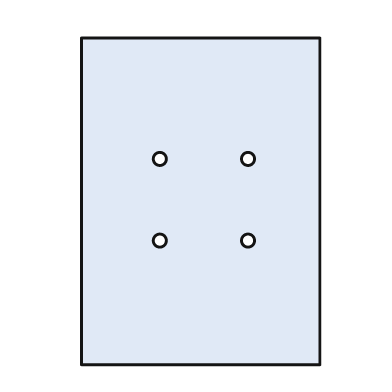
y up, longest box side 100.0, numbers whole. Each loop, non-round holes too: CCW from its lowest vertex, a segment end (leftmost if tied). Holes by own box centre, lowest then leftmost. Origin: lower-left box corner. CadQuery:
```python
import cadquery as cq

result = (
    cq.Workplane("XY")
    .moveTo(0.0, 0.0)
    .lineTo(73.0, 0.0)
    .lineTo(73.0, 100.0)
    .lineTo(0.0, 100.0)
    .close()
    .moveTo(24.0, 38.0)
    .circle(2.0)
    .moveTo(51.0, 38.0)
    .circle(2.0)
    .moveTo(24.0, 63.0)
    .circle(2.0)
    .moveTo(51.0, 63.0)
    .circle(2.0)
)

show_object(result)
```